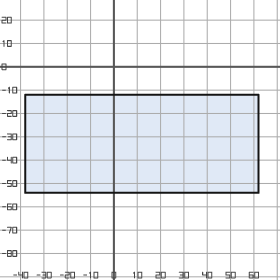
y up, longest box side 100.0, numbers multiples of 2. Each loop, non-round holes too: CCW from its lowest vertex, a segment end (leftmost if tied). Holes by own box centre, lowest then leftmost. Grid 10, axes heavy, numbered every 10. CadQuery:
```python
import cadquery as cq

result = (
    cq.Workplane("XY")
    .moveTo(-38.0, -54.0)
    .lineTo(62.0, -54.0)
    .lineTo(62.0, -12.0)
    .lineTo(-38.0, -12.0)
    .close()
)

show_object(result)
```